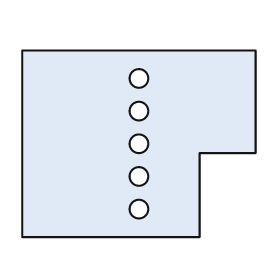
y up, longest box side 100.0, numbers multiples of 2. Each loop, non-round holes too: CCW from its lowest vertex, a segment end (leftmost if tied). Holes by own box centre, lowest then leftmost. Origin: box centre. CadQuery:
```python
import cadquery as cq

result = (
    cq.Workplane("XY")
    .moveTo(-50.0, -40.0)
    .lineTo(26.0, -40.0)
    .lineTo(26.0, -4.0)
    .lineTo(50.0, -4.0)
    .lineTo(50.0, 40.0)
    .lineTo(-50.0, 40.0)
    .close()
    .moveTo(0.0, -28.0)
    .circle(4.0)
    .moveTo(0.0, -14.0)
    .circle(4.0)
    .moveTo(0.0, 0.0)
    .circle(4.0)
    .moveTo(0.0, 14.0)
    .circle(4.0)
    .moveTo(0.0, 28.0)
    .circle(4.0)
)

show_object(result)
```